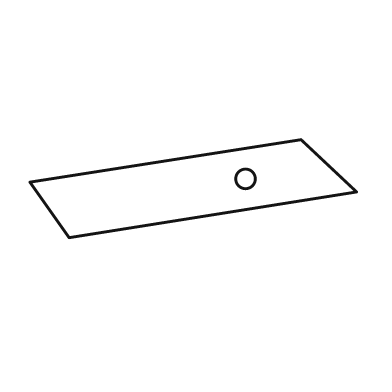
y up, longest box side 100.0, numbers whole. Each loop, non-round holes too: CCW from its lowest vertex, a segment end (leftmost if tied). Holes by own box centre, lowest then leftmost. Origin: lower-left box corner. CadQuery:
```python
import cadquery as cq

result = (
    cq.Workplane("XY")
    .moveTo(12.0, 0.0)
    .lineTo(100.0, 14.0)
    .lineTo(83.0, 30.0)
    .lineTo(0.0, 17.0)
    .close()
    .moveTo(66.0, 18.0)
    .circle(3.0)
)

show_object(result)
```